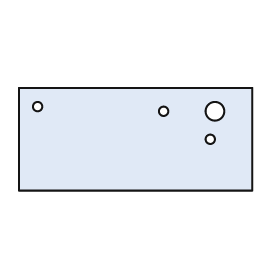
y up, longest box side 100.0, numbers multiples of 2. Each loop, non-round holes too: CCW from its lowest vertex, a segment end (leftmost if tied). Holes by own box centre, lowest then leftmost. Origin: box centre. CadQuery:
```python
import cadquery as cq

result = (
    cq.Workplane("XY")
    .moveTo(-50.0, -22.0)
    .lineTo(50.0, -22.0)
    .lineTo(50.0, 22.0)
    .lineTo(-50.0, 22.0)
    .close()
    .moveTo(32.0, 0.0)
    .circle(2.0)
    .moveTo(12.0, 12.0)
    .circle(2.0)
    .moveTo(34.0, 12.0)
    .circle(4.0)
    .moveTo(-42.0, 14.0)
    .circle(2.0)
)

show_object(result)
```